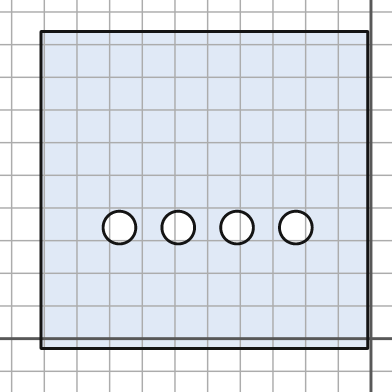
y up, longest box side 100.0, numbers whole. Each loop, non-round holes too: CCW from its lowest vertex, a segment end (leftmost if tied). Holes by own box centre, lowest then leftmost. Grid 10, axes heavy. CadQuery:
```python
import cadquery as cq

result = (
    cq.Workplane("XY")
    .moveTo(-101.0, -3.0)
    .lineTo(-1.0, -3.0)
    .lineTo(-1.0, 94.0)
    .lineTo(-101.0, 94.0)
    .close()
    .moveTo(-77.0, 34.0)
    .circle(5.0)
    .moveTo(-59.0, 34.0)
    .circle(5.0)
    .moveTo(-41.0, 34.0)
    .circle(5.0)
    .moveTo(-23.0, 34.0)
    .circle(5.0)
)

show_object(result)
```